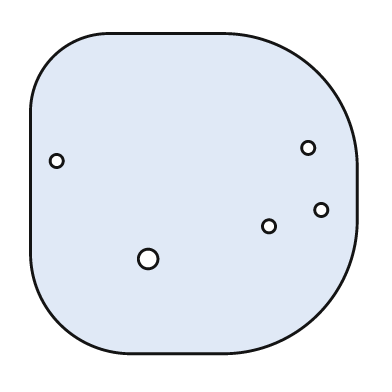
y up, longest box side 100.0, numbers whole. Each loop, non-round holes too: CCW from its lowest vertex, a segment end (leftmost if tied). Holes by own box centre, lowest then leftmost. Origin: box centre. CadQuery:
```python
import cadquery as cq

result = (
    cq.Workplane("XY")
    .moveTo(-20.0, -49.0)
    .lineTo(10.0, -49.0)
    .threePointArc((38.0, -37.0), (50.0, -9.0))
    .lineTo(50.0, 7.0)
    .threePointArc((38.0, 37.0), (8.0, 49.0))
    .lineTo(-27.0, 49.0)
    .threePointArc((-43.0, 42.0), (-50.0, 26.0))
    .lineTo(-50.0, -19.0)
    .threePointArc((-41.0, -40.0), (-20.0, -49.0))
    .close()
    .moveTo(-14.0, -20.0)
    .circle(3.0)
    .moveTo(23.0, -10.0)
    .circle(2.0)
    .moveTo(39.0, -5.0)
    .circle(2.0)
    .moveTo(-42.0, 10.0)
    .circle(2.0)
    .moveTo(35.0, 14.0)
    .circle(2.0)
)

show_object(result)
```